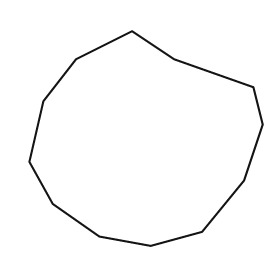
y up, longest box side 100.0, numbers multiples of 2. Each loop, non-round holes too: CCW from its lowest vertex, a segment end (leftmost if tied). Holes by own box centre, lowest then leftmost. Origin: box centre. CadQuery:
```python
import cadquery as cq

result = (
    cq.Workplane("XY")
    .moveTo(2.0, -46.0)
    .lineTo(24.0, -40.0)
    .lineTo(42.0, -18.0)
    .lineTo(50.0, 6.0)
    .lineTo(46.0, 22.0)
    .lineTo(12.0, 34.0)
    .lineTo(-6.0, 46.0)
    .lineTo(-30.0, 34.0)
    .lineTo(-44.0, 16.0)
    .lineTo(-50.0, -10.0)
    .lineTo(-40.0, -28.0)
    .lineTo(-20.0, -42.0)
    .close()
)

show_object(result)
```